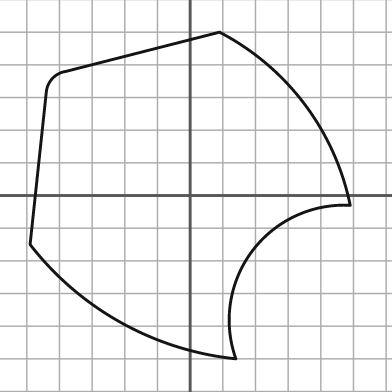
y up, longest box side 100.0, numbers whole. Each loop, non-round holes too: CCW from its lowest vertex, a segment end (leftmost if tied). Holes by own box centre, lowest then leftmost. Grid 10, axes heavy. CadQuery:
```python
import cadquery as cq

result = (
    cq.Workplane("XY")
    .moveTo(14.0, -50.0)
    .threePointArc((19.0, -17.0), (49.0, -3.0))
    .threePointArc((35.0, 28.0), (9.0, 50.0))
    .lineTo(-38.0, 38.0)
    .threePointArc((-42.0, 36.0), (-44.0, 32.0))
    .lineTo(-49.0, -15.0)
    .threePointArc((-21.0, -39.0), (14.0, -50.0))
    .close()
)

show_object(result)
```